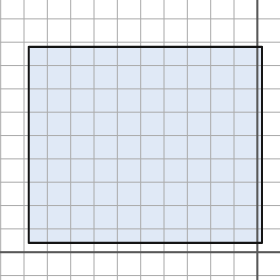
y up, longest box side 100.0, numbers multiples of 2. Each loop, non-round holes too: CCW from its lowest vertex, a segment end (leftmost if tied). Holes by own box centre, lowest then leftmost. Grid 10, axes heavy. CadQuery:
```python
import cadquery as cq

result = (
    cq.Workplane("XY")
    .moveTo(-98.0, 4.0)
    .lineTo(2.0, 4.0)
    .lineTo(2.0, 88.0)
    .lineTo(-98.0, 88.0)
    .close()
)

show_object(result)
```